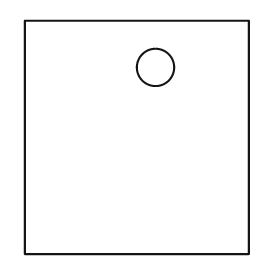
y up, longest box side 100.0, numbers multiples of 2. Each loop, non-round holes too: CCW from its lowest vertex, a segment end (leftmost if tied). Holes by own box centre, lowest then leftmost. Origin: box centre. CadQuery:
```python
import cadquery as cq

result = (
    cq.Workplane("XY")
    .moveTo(-48.0, -50.0)
    .lineTo(48.0, -50.0)
    .lineTo(48.0, 50.0)
    .lineTo(-48.0, 50.0)
    .close()
    .moveTo(8.0, 30.0)
    .circle(8.0)
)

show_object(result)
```